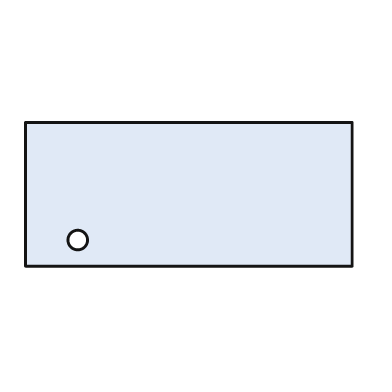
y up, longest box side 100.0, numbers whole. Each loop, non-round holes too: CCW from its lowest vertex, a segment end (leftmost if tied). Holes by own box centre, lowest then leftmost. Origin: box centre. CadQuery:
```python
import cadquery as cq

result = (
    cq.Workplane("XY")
    .moveTo(-50.0, -22.0)
    .lineTo(50.0, -22.0)
    .lineTo(50.0, 22.0)
    .lineTo(-50.0, 22.0)
    .close()
    .moveTo(-34.0, -14.0)
    .circle(3.0)
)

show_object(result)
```